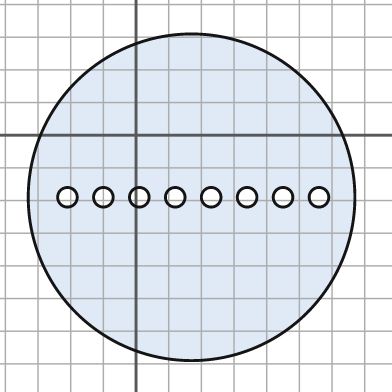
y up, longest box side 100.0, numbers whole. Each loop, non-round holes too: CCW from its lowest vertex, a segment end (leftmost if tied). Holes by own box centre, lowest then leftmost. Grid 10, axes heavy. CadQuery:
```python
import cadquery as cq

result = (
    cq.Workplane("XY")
    .moveTo(17.0, -19.0)
    .circle(50.0)
    .moveTo(-21.0, -19.0)
    .circle(3.0)
    .moveTo(-10.0, -19.0)
    .circle(3.0)
    .moveTo(1.0, -19.0)
    .circle(3.0)
    .moveTo(12.0, -19.0)
    .circle(3.0)
    .moveTo(23.0, -19.0)
    .circle(3.0)
    .moveTo(34.0, -19.0)
    .circle(3.0)
    .moveTo(45.0, -19.0)
    .circle(3.0)
    .moveTo(56.0, -19.0)
    .circle(3.0)
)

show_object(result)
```